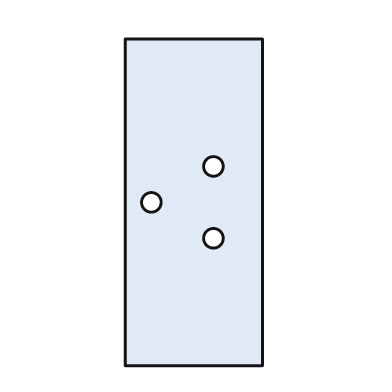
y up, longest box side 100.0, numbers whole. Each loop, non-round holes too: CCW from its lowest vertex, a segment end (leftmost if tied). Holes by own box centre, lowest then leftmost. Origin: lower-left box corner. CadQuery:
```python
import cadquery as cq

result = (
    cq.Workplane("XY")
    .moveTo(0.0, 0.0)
    .lineTo(42.0, 0.0)
    .lineTo(42.0, 100.0)
    .lineTo(0.0, 100.0)
    .close()
    .moveTo(27.0, 39.0)
    .circle(3.0)
    .moveTo(8.0, 50.0)
    .circle(3.0)
    .moveTo(27.0, 61.0)
    .circle(3.0)
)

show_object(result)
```